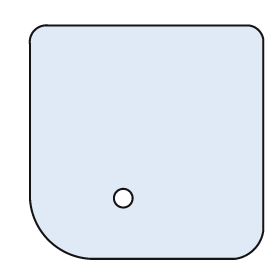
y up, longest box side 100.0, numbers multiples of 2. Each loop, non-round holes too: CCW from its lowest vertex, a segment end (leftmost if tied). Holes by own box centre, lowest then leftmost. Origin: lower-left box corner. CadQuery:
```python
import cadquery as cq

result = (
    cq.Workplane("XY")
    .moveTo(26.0, 0.0)
    .lineTo(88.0, 0.0)
    .threePointArc((96.0, 4.0), (100.0, 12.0))
    .lineTo(100.0, 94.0)
    .threePointArc((98.0, 98.0), (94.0, 100.0))
    .lineTo(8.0, 100.0)
    .threePointArc((2.0, 98.0), (0.0, 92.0))
    .lineTo(0.0, 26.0)
    .threePointArc((8.0, 8.0), (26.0, 0.0))
    .close()
    .moveTo(40.0, 26.0)
    .circle(4.0)
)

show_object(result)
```